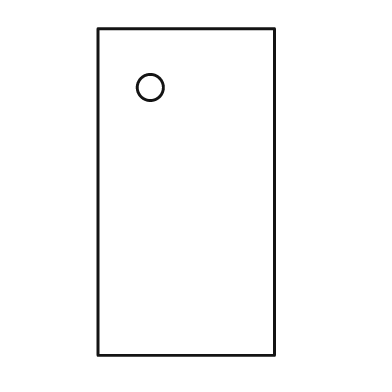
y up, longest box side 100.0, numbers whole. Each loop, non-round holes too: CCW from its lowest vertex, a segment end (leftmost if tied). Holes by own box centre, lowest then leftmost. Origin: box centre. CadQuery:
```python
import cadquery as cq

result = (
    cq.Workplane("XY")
    .moveTo(-27.0, -50.0)
    .lineTo(27.0, -50.0)
    .lineTo(27.0, 50.0)
    .lineTo(-27.0, 50.0)
    .close()
    .moveTo(-11.0, 32.0)
    .circle(4.0)
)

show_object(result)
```